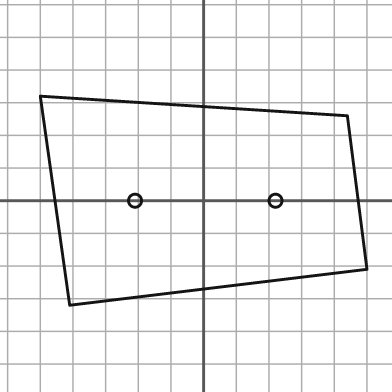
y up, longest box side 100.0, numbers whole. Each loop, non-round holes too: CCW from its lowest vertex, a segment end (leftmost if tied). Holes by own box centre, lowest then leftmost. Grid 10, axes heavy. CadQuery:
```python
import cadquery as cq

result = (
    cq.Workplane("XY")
    .moveTo(-41.0, -32.0)
    .lineTo(50.0, -21.0)
    .lineTo(44.0, 26.0)
    .lineTo(-50.0, 32.0)
    .close()
    .moveTo(-21.0, 0.0)
    .circle(2.0)
    .moveTo(22.0, 0.0)
    .circle(2.0)
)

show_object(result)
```